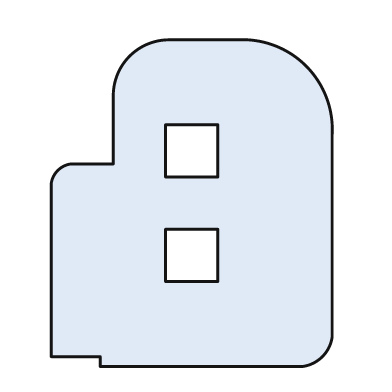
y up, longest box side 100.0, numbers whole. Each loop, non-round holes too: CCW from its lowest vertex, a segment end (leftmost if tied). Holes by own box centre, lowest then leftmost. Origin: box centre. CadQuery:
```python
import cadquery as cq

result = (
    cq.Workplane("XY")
    .moveTo(-28.0, -50.0)
    .lineTo(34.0, -50.0)
    .threePointArc((40.0, -47.0), (43.0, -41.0))
    .lineTo(43.0, 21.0)
    .threePointArc((35.0, 42.0), (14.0, 50.0))
    .lineTo(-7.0, 50.0)
    .threePointArc((-19.0, 45.0), (-24.0, 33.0))
    .lineTo(-24.0, 12.0)
    .lineTo(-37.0, 12.0)
    .threePointArc((-41.0, 10.0), (-43.0, 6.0))
    .lineTo(-43.0, -47.0)
    .lineTo(-28.0, -47.0)
    .close()
    .moveTo(-8.0, -24.0)
    .lineTo(8.0, -24.0)
    .lineTo(8.0, -8.0)
    .lineTo(-8.0, -8.0)
    .close()
    .moveTo(-8.0, 8.0)
    .lineTo(8.0, 8.0)
    .lineTo(8.0, 24.0)
    .lineTo(-8.0, 24.0)
    .close()
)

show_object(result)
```